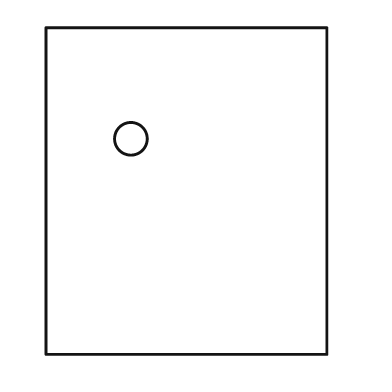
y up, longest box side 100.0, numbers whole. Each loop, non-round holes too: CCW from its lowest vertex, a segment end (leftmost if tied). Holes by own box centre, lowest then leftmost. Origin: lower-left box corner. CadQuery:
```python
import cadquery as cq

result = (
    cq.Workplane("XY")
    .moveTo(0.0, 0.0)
    .lineTo(86.0, 0.0)
    .lineTo(86.0, 100.0)
    .lineTo(0.0, 100.0)
    .close()
    .moveTo(26.0, 66.0)
    .circle(5.0)
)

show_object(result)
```